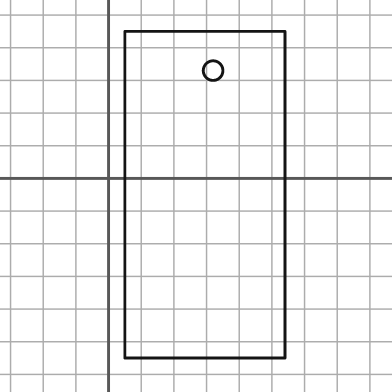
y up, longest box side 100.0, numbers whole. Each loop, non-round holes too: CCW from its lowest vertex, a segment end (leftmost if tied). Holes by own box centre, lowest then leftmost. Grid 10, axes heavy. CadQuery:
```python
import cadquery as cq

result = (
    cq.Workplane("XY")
    .moveTo(5.0, -55.0)
    .lineTo(54.0, -55.0)
    .lineTo(54.0, 45.0)
    .lineTo(5.0, 45.0)
    .close()
    .moveTo(32.0, 33.0)
    .circle(3.0)
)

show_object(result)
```